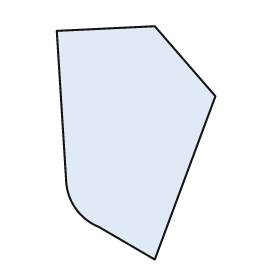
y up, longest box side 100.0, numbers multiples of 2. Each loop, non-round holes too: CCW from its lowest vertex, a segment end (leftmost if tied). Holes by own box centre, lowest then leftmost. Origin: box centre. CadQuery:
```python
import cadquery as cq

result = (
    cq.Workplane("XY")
    .moveTo(8.0, -50.0)
    .lineTo(34.0, 20.0)
    .lineTo(8.0, 50.0)
    .lineTo(-34.0, 48.0)
    .lineTo(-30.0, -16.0)
    .threePointArc((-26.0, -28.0), (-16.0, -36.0))
    .close()
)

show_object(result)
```